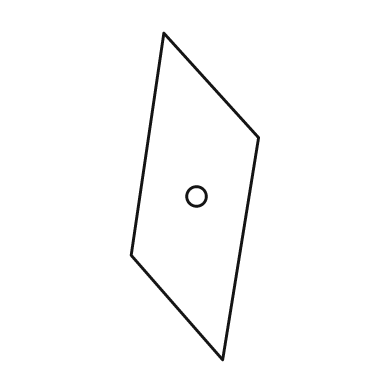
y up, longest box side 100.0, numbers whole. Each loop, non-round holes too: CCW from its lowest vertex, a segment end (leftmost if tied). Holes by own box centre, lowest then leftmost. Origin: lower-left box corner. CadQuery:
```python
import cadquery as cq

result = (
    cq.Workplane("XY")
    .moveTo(28.0, 0.0)
    .lineTo(39.0, 68.0)
    .lineTo(10.0, 100.0)
    .lineTo(0.0, 32.0)
    .close()
    .moveTo(20.0, 50.0)
    .circle(3.0)
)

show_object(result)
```